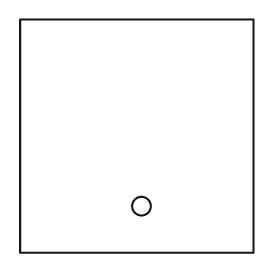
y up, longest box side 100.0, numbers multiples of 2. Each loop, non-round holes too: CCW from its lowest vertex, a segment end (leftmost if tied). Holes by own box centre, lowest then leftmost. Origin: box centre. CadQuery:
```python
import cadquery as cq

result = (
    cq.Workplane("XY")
    .moveTo(-50.0, -50.0)
    .lineTo(50.0, -50.0)
    .lineTo(50.0, 50.0)
    .lineTo(-50.0, 50.0)
    .close()
    .moveTo(2.0, -30.0)
    .circle(4.0)
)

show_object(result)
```